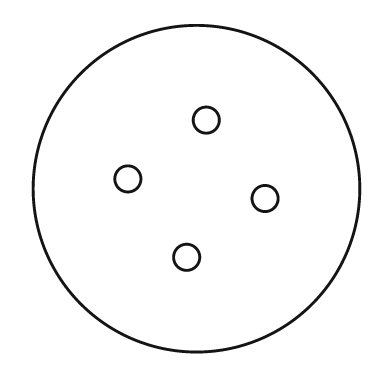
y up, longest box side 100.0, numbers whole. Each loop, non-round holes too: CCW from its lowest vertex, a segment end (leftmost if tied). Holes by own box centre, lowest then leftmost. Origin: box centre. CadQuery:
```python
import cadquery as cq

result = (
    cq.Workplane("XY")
    .moveTo(0.0, 0.0)
    .circle(50.0)
    .moveTo(-3.0, -21.0)
    .circle(4.0)
    .moveTo(21.0, -3.0)
    .circle(4.0)
    .moveTo(-21.0, 3.0)
    .circle(4.0)
    .moveTo(3.0, 21.0)
    .circle(4.0)
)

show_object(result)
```